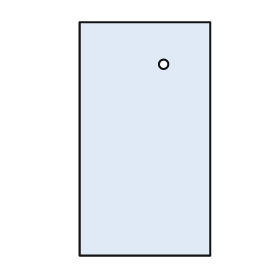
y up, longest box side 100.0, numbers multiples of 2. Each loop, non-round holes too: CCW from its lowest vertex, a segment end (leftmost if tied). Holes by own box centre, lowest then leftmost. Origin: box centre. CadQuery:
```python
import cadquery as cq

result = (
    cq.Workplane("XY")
    .moveTo(-28.0, -50.0)
    .lineTo(28.0, -50.0)
    .lineTo(28.0, 50.0)
    .lineTo(-28.0, 50.0)
    .close()
    .moveTo(8.0, 32.0)
    .circle(2.0)
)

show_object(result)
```